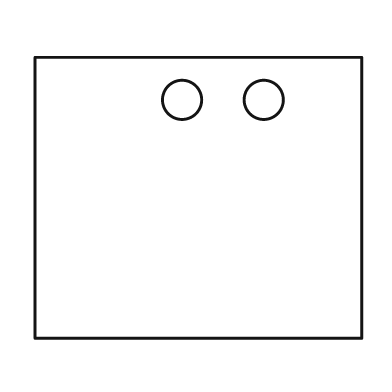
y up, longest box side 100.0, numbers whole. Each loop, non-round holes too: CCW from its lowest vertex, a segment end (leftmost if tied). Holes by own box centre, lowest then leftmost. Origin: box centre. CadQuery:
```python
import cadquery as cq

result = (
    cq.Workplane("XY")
    .moveTo(-50.0, -43.0)
    .lineTo(50.0, -43.0)
    .lineTo(50.0, 43.0)
    .lineTo(-50.0, 43.0)
    .close()
    .moveTo(-5.0, 30.0)
    .circle(6.0)
    .moveTo(20.0, 30.0)
    .circle(6.0)
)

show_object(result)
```